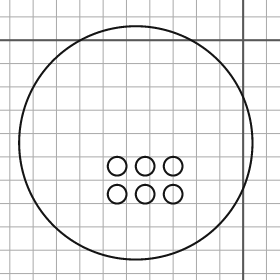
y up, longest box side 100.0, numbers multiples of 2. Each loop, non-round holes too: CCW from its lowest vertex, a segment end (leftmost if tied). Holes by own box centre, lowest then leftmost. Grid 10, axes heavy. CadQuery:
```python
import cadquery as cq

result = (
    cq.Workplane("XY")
    .moveTo(-46.0, -44.0)
    .circle(50.0)
    .moveTo(-54.0, -66.0)
    .circle(4.0)
    .moveTo(-42.0, -66.0)
    .circle(4.0)
    .moveTo(-30.0, -66.0)
    .circle(4.0)
    .moveTo(-54.0, -54.0)
    .circle(4.0)
    .moveTo(-42.0, -54.0)
    .circle(4.0)
    .moveTo(-30.0, -54.0)
    .circle(4.0)
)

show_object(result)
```